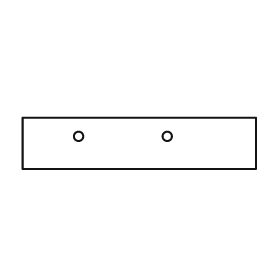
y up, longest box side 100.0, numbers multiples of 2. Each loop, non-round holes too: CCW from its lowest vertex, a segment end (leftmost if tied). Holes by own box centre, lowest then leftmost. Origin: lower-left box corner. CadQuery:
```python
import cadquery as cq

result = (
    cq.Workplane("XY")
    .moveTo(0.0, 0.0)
    .lineTo(100.0, 0.0)
    .lineTo(100.0, 22.0)
    .lineTo(0.0, 22.0)
    .close()
    .moveTo(24.0, 14.0)
    .circle(2.0)
    .moveTo(62.0, 14.0)
    .circle(2.0)
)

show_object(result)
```